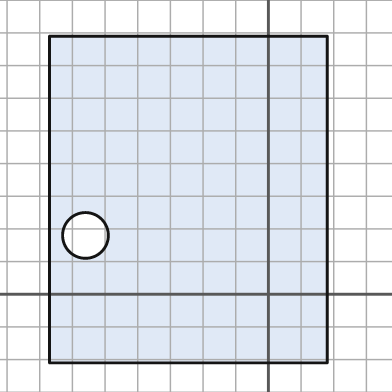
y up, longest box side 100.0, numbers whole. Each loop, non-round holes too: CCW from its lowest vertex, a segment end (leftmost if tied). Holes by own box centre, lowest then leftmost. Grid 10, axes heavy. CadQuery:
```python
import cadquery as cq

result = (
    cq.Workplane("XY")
    .moveTo(-67.0, -21.0)
    .lineTo(18.0, -21.0)
    .lineTo(18.0, 79.0)
    .lineTo(-67.0, 79.0)
    .close()
    .moveTo(-56.0, 18.0)
    .circle(7.0)
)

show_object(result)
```